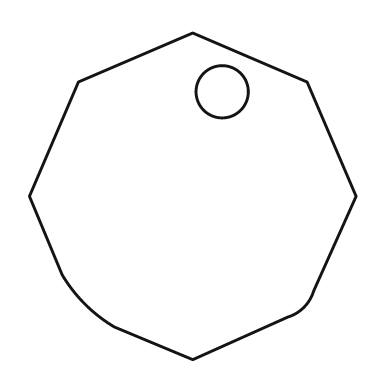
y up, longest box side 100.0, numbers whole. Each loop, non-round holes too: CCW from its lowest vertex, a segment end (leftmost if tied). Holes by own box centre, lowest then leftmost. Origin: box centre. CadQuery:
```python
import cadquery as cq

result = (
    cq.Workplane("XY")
    .moveTo(0.0, -50.0)
    .lineTo(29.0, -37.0)
    .threePointArc((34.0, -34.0), (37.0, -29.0))
    .lineTo(50.0, 0.0)
    .lineTo(35.0, 35.0)
    .lineTo(0.0, 50.0)
    .lineTo(-35.0, 35.0)
    .lineTo(-50.0, 0.0)
    .lineTo(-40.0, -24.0)
    .threePointArc((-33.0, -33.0), (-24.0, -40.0))
    .close()
    .moveTo(9.0, 32.0)
    .circle(8.0)
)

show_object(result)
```